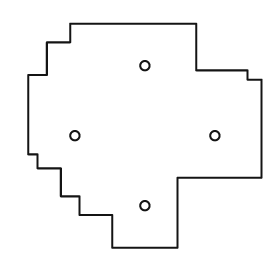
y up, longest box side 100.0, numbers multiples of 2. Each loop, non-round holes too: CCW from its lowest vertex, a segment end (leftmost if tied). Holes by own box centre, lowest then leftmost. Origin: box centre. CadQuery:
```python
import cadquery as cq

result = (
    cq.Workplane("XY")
    .moveTo(-14.0, -48.0)
    .lineTo(14.0, -48.0)
    .lineTo(14.0, -18.0)
    .lineTo(50.0, -18.0)
    .lineTo(50.0, 24.0)
    .lineTo(44.0, 24.0)
    .lineTo(44.0, 28.0)
    .lineTo(22.0, 28.0)
    .lineTo(22.0, 48.0)
    .lineTo(-32.0, 48.0)
    .lineTo(-32.0, 40.0)
    .lineTo(-42.0, 40.0)
    .lineTo(-42.0, 26.0)
    .lineTo(-50.0, 26.0)
    .lineTo(-50.0, -8.0)
    .lineTo(-46.0, -8.0)
    .lineTo(-46.0, -14.0)
    .lineTo(-36.0, -14.0)
    .lineTo(-36.0, -26.0)
    .lineTo(-28.0, -26.0)
    .lineTo(-28.0, -34.0)
    .lineTo(-14.0, -34.0)
    .close()
    .moveTo(0.0, -30.0)
    .circle(2.0)
    .moveTo(-30.0, 0.0)
    .circle(2.0)
    .moveTo(30.0, 0.0)
    .circle(2.0)
    .moveTo(0.0, 30.0)
    .circle(2.0)
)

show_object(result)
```